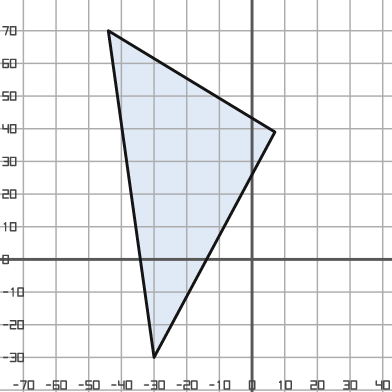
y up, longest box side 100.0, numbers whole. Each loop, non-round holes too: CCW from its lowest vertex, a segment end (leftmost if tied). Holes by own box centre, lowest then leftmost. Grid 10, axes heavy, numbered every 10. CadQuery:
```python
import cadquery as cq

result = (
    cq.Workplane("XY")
    .moveTo(-30.0, -30.0)
    .lineTo(7.0, 39.0)
    .lineTo(-44.0, 70.0)
    .close()
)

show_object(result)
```